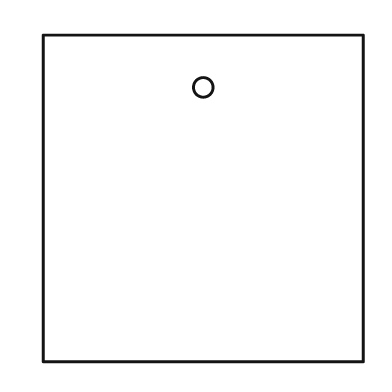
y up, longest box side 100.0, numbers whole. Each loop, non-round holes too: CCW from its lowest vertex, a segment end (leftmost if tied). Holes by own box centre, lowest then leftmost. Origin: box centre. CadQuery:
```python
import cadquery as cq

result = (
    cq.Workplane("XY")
    .moveTo(-49.0, -50.0)
    .lineTo(49.0, -50.0)
    .lineTo(49.0, 50.0)
    .lineTo(-49.0, 50.0)
    .close()
    .moveTo(0.0, 34.0)
    .circle(3.0)
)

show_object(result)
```